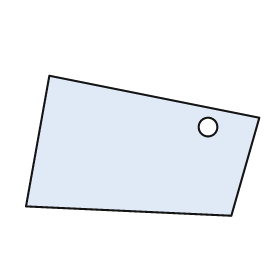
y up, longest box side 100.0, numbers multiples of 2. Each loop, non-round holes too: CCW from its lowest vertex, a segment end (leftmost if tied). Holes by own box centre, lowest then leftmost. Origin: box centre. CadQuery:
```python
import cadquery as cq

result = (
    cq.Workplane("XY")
    .moveTo(38.0, -30.0)
    .lineTo(50.0, 12.0)
    .lineTo(-40.0, 30.0)
    .lineTo(-50.0, -26.0)
    .close()
    .moveTo(28.0, 8.0)
    .circle(4.0)
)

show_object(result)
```